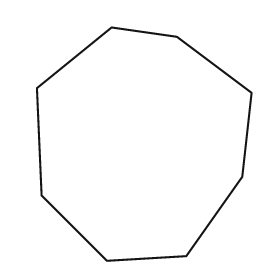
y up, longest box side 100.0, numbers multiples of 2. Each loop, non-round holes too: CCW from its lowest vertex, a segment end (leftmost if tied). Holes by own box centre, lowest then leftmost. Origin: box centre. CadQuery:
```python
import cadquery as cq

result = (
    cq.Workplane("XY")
    .moveTo(-16.0, -50.0)
    .lineTo(18.0, -48.0)
    .lineTo(42.0, -14.0)
    .lineTo(46.0, 22.0)
    .lineTo(14.0, 46.0)
    .lineTo(-14.0, 50.0)
    .lineTo(-46.0, 24.0)
    .lineTo(-44.0, -22.0)
    .close()
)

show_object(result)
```